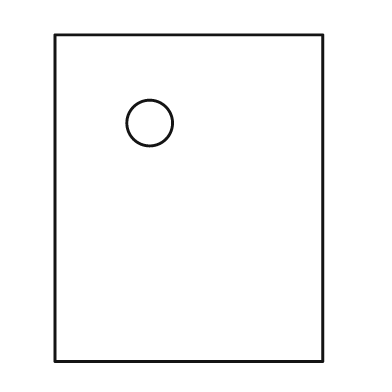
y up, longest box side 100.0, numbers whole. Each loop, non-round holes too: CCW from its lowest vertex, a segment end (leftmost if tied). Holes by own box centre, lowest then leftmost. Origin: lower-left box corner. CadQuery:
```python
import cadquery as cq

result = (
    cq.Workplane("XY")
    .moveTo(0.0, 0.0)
    .lineTo(82.0, 0.0)
    .lineTo(82.0, 100.0)
    .lineTo(0.0, 100.0)
    .close()
    .moveTo(29.0, 73.0)
    .circle(7.0)
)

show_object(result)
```